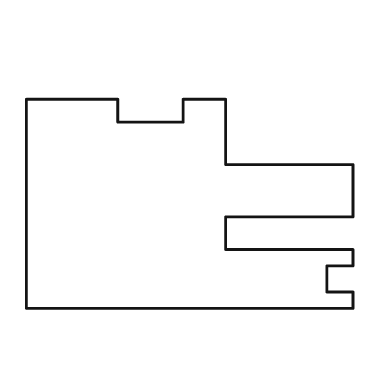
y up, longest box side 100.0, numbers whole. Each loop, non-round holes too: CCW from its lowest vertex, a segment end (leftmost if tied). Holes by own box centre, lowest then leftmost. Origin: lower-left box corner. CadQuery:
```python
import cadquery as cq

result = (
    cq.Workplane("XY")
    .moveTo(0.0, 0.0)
    .lineTo(100.0, 0.0)
    .lineTo(100.0, 5.0)
    .lineTo(92.0, 5.0)
    .lineTo(92.0, 13.0)
    .lineTo(100.0, 13.0)
    .lineTo(100.0, 18.0)
    .lineTo(61.0, 18.0)
    .lineTo(61.0, 28.0)
    .lineTo(100.0, 28.0)
    .lineTo(100.0, 44.0)
    .lineTo(61.0, 44.0)
    .lineTo(61.0, 64.0)
    .lineTo(48.0, 64.0)
    .lineTo(48.0, 57.0)
    .lineTo(28.0, 57.0)
    .lineTo(28.0, 64.0)
    .lineTo(0.0, 64.0)
    .close()
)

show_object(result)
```